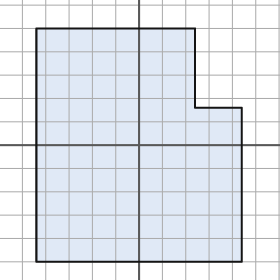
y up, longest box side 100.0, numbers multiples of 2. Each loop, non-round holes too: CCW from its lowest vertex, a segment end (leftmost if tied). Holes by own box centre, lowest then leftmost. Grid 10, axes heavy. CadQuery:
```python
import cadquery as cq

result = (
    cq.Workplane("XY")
    .moveTo(-44.0, -50.0)
    .lineTo(44.0, -50.0)
    .lineTo(44.0, 16.0)
    .lineTo(24.0, 16.0)
    .lineTo(24.0, 50.0)
    .lineTo(-44.0, 50.0)
    .close()
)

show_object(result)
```